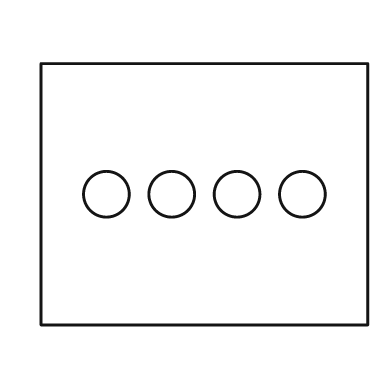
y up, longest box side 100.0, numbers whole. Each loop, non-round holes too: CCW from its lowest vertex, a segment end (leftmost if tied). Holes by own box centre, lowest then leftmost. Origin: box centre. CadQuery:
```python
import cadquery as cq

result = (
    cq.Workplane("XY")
    .moveTo(-50.0, -40.0)
    .lineTo(50.0, -40.0)
    .lineTo(50.0, 40.0)
    .lineTo(-50.0, 40.0)
    .close()
    .moveTo(-30.0, 0.0)
    .circle(7.0)
    .moveTo(-10.0, 0.0)
    .circle(7.0)
    .moveTo(10.0, 0.0)
    .circle(7.0)
    .moveTo(30.0, 0.0)
    .circle(7.0)
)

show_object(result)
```